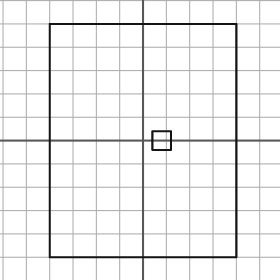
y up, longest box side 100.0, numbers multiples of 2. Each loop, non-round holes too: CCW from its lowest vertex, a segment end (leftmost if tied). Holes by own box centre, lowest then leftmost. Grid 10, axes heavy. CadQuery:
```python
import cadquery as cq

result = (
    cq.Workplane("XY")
    .moveTo(-40.0, -50.0)
    .lineTo(40.0, -50.0)
    .lineTo(40.0, 50.0)
    .lineTo(-40.0, 50.0)
    .close()
    .moveTo(4.0, -4.0)
    .lineTo(12.0, -4.0)
    .lineTo(12.0, 4.0)
    .lineTo(4.0, 4.0)
    .close()
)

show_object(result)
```